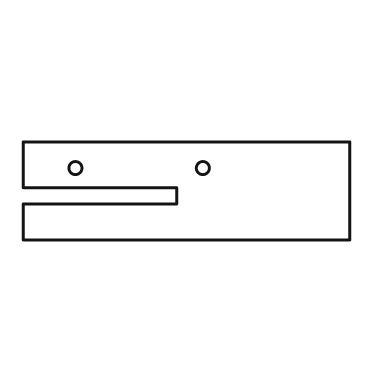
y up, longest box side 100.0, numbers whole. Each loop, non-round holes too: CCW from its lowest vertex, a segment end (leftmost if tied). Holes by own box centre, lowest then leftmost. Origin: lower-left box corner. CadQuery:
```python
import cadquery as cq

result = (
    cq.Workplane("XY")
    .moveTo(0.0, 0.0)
    .lineTo(100.0, 0.0)
    .lineTo(100.0, 30.0)
    .lineTo(0.0, 30.0)
    .lineTo(0.0, 16.0)
    .lineTo(47.0, 16.0)
    .lineTo(47.0, 11.0)
    .lineTo(0.0, 11.0)
    .close()
    .moveTo(16.0, 22.0)
    .circle(2.0)
    .moveTo(55.0, 22.0)
    .circle(2.0)
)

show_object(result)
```